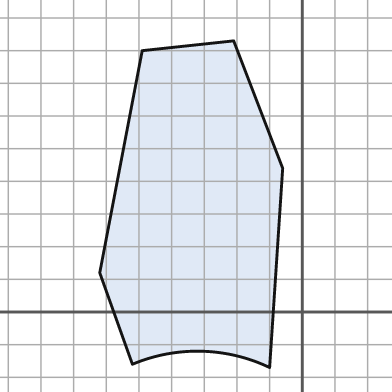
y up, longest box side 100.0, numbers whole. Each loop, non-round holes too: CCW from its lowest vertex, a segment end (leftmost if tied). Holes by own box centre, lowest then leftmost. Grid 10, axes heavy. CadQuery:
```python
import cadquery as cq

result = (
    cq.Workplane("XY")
    .moveTo(-10.0, -17.0)
    .lineTo(-6.0, 44.0)
    .lineTo(-21.0, 83.0)
    .lineTo(-49.0, 80.0)
    .lineTo(-62.0, 12.0)
    .lineTo(-52.0, -16.0)
    .threePointArc((-31.0, -12.0), (-10.0, -17.0))
    .close()
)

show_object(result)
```